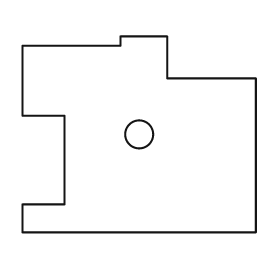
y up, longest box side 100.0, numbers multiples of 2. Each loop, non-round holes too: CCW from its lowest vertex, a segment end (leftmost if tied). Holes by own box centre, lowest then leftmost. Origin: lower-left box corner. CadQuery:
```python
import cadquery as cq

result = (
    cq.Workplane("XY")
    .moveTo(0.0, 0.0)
    .lineTo(100.0, 0.0)
    .lineTo(100.0, 66.0)
    .lineTo(62.0, 66.0)
    .lineTo(62.0, 84.0)
    .lineTo(42.0, 84.0)
    .lineTo(42.0, 80.0)
    .lineTo(0.0, 80.0)
    .lineTo(0.0, 50.0)
    .lineTo(18.0, 50.0)
    .lineTo(18.0, 12.0)
    .lineTo(0.0, 12.0)
    .close()
    .moveTo(50.0, 42.0)
    .circle(6.0)
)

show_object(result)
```